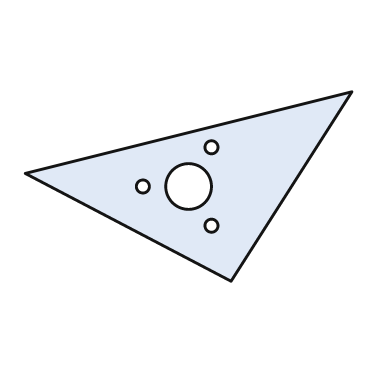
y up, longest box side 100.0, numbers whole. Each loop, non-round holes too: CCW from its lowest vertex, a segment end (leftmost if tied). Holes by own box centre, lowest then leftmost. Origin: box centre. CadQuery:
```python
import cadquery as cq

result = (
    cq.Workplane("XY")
    .moveTo(13.0, -29.0)
    .lineTo(50.0, 29.0)
    .lineTo(-50.0, 4.0)
    .close()
    .moveTo(7.0, -12.0)
    .circle(2.0)
    .moveTo(-14.0, 0.0)
    .circle(2.0)
    .moveTo(0.0, 0.0)
    .circle(7.0)
    .moveTo(7.0, 12.0)
    .circle(2.0)
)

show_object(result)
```